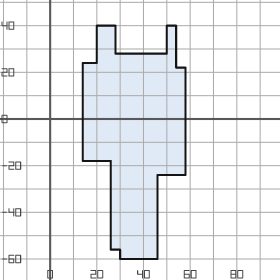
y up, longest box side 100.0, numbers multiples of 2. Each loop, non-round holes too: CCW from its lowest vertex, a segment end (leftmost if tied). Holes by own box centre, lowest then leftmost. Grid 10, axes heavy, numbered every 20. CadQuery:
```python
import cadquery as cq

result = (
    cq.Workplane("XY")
    .moveTo(30.0, -60.0)
    .lineTo(46.0, -60.0)
    .lineTo(46.0, -24.0)
    .lineTo(58.0, -24.0)
    .lineTo(58.0, 22.0)
    .lineTo(54.0, 22.0)
    .lineTo(54.0, 40.0)
    .lineTo(50.0, 40.0)
    .lineTo(50.0, 28.0)
    .lineTo(28.0, 28.0)
    .lineTo(28.0, 40.0)
    .lineTo(20.0, 40.0)
    .lineTo(20.0, 24.0)
    .lineTo(14.0, 24.0)
    .lineTo(14.0, -18.0)
    .lineTo(26.0, -18.0)
    .lineTo(26.0, -56.0)
    .lineTo(30.0, -56.0)
    .close()
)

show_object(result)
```